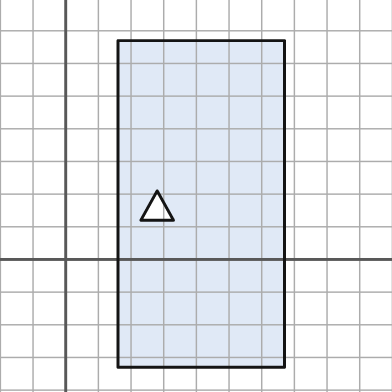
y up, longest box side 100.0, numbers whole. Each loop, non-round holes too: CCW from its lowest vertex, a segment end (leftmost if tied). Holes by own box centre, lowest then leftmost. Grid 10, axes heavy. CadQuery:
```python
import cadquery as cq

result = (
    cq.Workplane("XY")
    .moveTo(16.0, -33.0)
    .lineTo(67.0, -33.0)
    .lineTo(67.0, 67.0)
    .lineTo(16.0, 67.0)
    .close()
    .moveTo(23.0, 12.0)
    .lineTo(33.0, 12.0)
    .lineTo(28.0, 21.0)
    .close()
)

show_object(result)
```